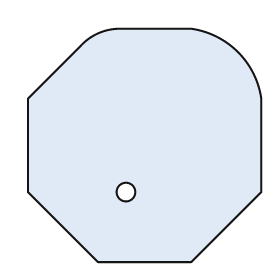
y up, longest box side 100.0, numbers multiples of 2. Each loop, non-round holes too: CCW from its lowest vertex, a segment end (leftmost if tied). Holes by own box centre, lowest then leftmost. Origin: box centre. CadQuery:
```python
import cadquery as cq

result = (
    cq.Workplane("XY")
    .moveTo(-20.0, -50.0)
    .lineTo(20.0, -50.0)
    .lineTo(50.0, -20.0)
    .lineTo(50.0, 20.0)
    .threePointArc((40.0, 40.0), (20.0, 50.0))
    .lineTo(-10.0, 50.0)
    .threePointArc((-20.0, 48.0), (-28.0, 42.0))
    .lineTo(-50.0, 20.0)
    .lineTo(-50.0, -20.0)
    .close()
    .moveTo(-8.0, -20.0)
    .circle(4.0)
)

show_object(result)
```